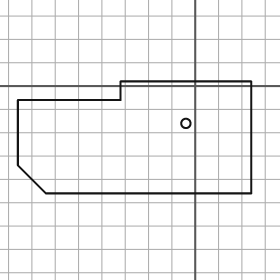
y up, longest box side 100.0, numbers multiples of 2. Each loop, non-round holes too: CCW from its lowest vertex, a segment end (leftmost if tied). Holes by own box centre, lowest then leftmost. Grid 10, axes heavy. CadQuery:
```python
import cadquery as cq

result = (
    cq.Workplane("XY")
    .moveTo(-64.0, -46.0)
    .lineTo(24.0, -46.0)
    .lineTo(24.0, 2.0)
    .lineTo(-32.0, 2.0)
    .lineTo(-32.0, -6.0)
    .lineTo(-76.0, -6.0)
    .lineTo(-76.0, -34.0)
    .close()
    .moveTo(-4.0, -16.0)
    .circle(2.0)
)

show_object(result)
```